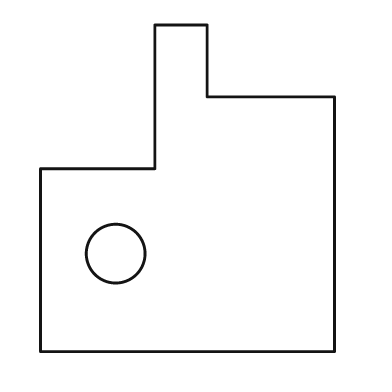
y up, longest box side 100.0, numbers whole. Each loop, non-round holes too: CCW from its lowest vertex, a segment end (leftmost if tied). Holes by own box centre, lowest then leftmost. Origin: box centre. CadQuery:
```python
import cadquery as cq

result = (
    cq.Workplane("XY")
    .moveTo(-45.0, -50.0)
    .lineTo(45.0, -50.0)
    .lineTo(45.0, 28.0)
    .lineTo(6.0, 28.0)
    .lineTo(6.0, 50.0)
    .lineTo(-10.0, 50.0)
    .lineTo(-10.0, 6.0)
    .lineTo(-45.0, 6.0)
    .close()
    .moveTo(-22.0, -20.0)
    .circle(9.0)
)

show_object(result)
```